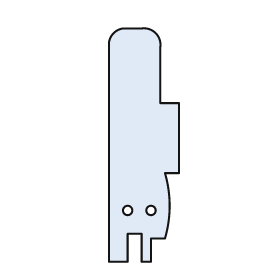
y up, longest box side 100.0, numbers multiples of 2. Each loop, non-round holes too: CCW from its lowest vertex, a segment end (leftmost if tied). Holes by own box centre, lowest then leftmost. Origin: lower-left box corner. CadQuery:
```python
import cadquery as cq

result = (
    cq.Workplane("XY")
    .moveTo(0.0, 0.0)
    .lineTo(8.0, 0.0)
    .lineTo(8.0, 12.0)
    .lineTo(14.0, 12.0)
    .lineTo(14.0, 0.0)
    .lineTo(18.0, 0.0)
    .lineTo(18.0, 10.0)
    .lineTo(24.0, 10.0)
    .threePointArc((26.0, 24.0), (24.0, 38.0))
    .lineTo(30.0, 38.0)
    .lineTo(30.0, 68.0)
    .lineTo(22.0, 68.0)
    .lineTo(22.0, 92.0)
    .threePointArc((20.0, 98.0), (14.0, 100.0))
    .lineTo(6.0, 100.0)
    .threePointArc((2.0, 98.0), (0.0, 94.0))
    .close()
    .moveTo(8.0, 22.0)
    .circle(2.0)
    .moveTo(18.0, 22.0)
    .circle(2.0)
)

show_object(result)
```